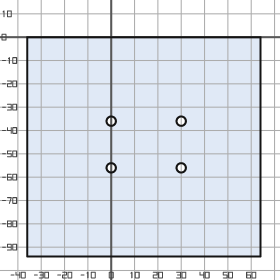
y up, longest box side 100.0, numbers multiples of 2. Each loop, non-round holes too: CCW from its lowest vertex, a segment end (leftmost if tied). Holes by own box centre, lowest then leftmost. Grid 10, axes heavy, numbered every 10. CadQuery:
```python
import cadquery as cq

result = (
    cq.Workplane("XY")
    .moveTo(-36.0, -94.0)
    .lineTo(64.0, -94.0)
    .lineTo(64.0, 0.0)
    .lineTo(-36.0, 0.0)
    .close()
    .moveTo(0.0, -56.0)
    .circle(2.0)
    .moveTo(30.0, -56.0)
    .circle(2.0)
    .moveTo(0.0, -36.0)
    .circle(2.0)
    .moveTo(30.0, -36.0)
    .circle(2.0)
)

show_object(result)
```